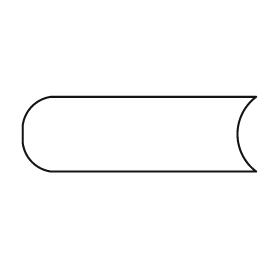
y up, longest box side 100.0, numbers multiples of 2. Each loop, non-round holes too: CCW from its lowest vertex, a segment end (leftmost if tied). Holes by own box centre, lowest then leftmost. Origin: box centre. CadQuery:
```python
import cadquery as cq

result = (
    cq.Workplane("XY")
    .moveTo(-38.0, -16.0)
    .lineTo(50.0, -16.0)
    .threePointArc((42.0, 0.0), (50.0, 16.0))
    .lineTo(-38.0, 16.0)
    .threePointArc((-46.0, 12.0), (-50.0, 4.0))
    .lineTo(-50.0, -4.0)
    .threePointArc((-46.0, -12.0), (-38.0, -16.0))
    .close()
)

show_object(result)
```